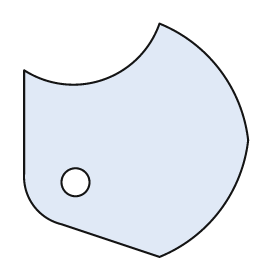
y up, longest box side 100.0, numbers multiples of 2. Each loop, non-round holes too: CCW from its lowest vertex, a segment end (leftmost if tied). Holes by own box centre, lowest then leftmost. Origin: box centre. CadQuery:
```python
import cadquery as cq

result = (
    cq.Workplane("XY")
    .moveTo(10.0, -50.0)
    .threePointArc((36.0, -30.0), (48.0, 0.0))
    .threePointArc((36.0, 30.0), (10.0, 50.0))
    .threePointArc((-14.0, 26.0), (-48.0, 30.0))
    .lineTo(-48.0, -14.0)
    .threePointArc((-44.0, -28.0), (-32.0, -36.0))
    .close()
    .moveTo(-26.0, -18.0)
    .circle(6.0)
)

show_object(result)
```